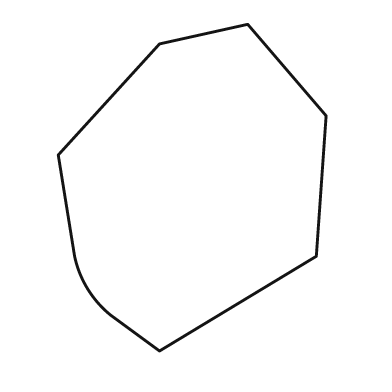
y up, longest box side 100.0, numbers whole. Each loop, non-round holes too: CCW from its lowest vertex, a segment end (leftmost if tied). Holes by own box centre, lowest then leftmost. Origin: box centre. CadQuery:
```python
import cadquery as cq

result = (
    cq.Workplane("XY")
    .moveTo(-10.0, -50.0)
    .lineTo(38.0, -21.0)
    .lineTo(41.0, 22.0)
    .lineTo(17.0, 50.0)
    .lineTo(-10.0, 44.0)
    .lineTo(-41.0, 10.0)
    .lineTo(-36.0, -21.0)
    .threePointArc((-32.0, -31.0), (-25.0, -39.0))
    .close()
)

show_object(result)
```